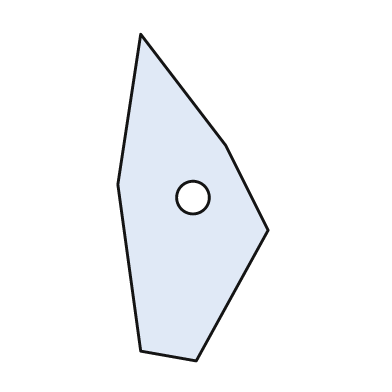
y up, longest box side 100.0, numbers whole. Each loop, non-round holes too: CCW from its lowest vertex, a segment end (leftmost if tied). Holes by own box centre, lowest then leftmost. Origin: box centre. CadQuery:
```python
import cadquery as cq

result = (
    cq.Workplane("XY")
    .moveTo(1.0, -50.0)
    .lineTo(23.0, -10.0)
    .lineTo(10.0, 16.0)
    .lineTo(-16.0, 50.0)
    .lineTo(-23.0, 4.0)
    .lineTo(-16.0, -47.0)
    .close()
    .moveTo(0.0, 0.0)
    .circle(5.0)
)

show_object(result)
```